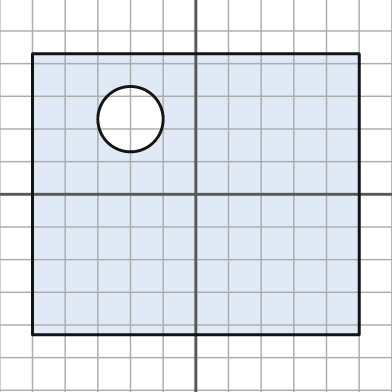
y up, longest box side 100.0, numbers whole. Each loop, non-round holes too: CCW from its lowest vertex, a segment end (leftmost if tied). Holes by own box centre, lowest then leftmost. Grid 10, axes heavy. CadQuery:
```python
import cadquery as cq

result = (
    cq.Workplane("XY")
    .moveTo(-50.0, -43.0)
    .lineTo(50.0, -43.0)
    .lineTo(50.0, 43.0)
    .lineTo(-50.0, 43.0)
    .close()
    .moveTo(-20.0, 23.0)
    .circle(10.0)
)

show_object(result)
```